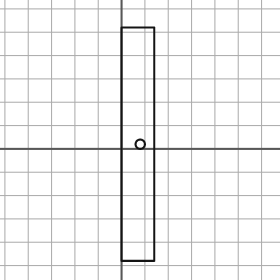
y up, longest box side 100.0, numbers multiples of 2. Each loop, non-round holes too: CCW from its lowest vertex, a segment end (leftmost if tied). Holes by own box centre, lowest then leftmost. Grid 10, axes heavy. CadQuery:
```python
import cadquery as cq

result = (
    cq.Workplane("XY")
    .moveTo(0.0, -48.0)
    .lineTo(14.0, -48.0)
    .lineTo(14.0, 52.0)
    .lineTo(0.0, 52.0)
    .close()
    .moveTo(8.0, 2.0)
    .circle(2.0)
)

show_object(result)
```